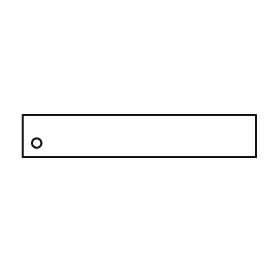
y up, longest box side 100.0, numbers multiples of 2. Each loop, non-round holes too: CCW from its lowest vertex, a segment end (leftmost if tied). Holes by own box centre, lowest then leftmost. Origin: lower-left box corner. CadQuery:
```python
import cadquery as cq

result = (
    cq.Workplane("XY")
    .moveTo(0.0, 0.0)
    .lineTo(100.0, 0.0)
    .lineTo(100.0, 18.0)
    .lineTo(0.0, 18.0)
    .close()
    .moveTo(6.0, 6.0)
    .circle(2.0)
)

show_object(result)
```